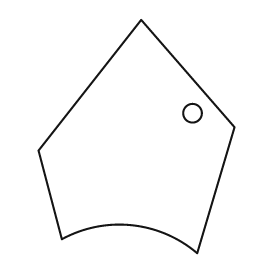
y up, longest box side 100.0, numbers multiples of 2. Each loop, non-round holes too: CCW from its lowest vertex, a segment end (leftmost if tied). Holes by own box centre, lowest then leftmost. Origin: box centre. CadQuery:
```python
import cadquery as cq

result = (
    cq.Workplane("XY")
    .moveTo(26.0, -50.0)
    .lineTo(42.0, 4.0)
    .lineTo(2.0, 50.0)
    .lineTo(-42.0, -6.0)
    .lineTo(-32.0, -44.0)
    .threePointArc((-2.0, -38.0), (26.0, -50.0))
    .close()
    .moveTo(24.0, 10.0)
    .circle(4.0)
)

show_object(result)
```